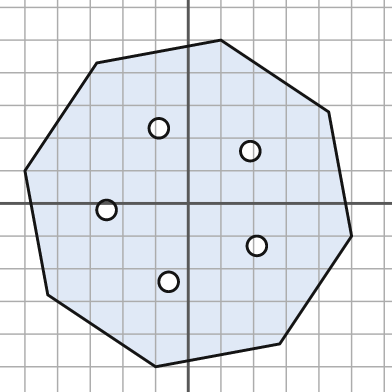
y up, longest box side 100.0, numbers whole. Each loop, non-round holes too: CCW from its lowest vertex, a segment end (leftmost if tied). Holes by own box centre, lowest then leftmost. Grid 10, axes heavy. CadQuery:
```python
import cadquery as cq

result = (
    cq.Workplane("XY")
    .moveTo(-10.0, -50.0)
    .lineTo(28.0, -43.0)
    .lineTo(50.0, -10.0)
    .lineTo(43.0, 28.0)
    .lineTo(10.0, 50.0)
    .lineTo(-28.0, 43.0)
    .lineTo(-50.0, 10.0)
    .lineTo(-43.0, -28.0)
    .close()
    .moveTo(-6.0, -24.0)
    .circle(3.0)
    .moveTo(21.0, -13.0)
    .circle(3.0)
    .moveTo(-25.0, -2.0)
    .circle(3.0)
    .moveTo(19.0, 16.0)
    .circle(3.0)
    .moveTo(-9.0, 23.0)
    .circle(3.0)
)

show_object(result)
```